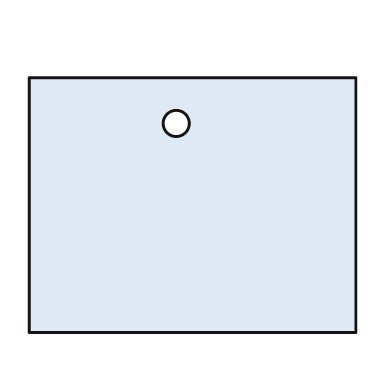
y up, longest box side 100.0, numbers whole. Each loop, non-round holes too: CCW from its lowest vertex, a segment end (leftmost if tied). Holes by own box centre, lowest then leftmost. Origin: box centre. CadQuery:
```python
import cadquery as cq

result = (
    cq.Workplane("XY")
    .moveTo(-50.0, -39.0)
    .lineTo(50.0, -39.0)
    .lineTo(50.0, 39.0)
    .lineTo(-50.0, 39.0)
    .close()
    .moveTo(-5.0, 25.0)
    .circle(4.0)
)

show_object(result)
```